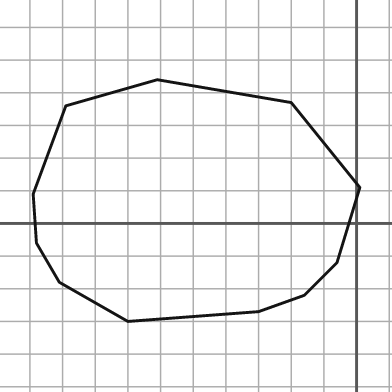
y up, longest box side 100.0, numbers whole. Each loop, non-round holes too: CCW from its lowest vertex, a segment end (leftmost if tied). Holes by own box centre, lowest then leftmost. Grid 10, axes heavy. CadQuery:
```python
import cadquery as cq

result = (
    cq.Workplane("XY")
    .moveTo(-70.0, -30.0)
    .lineTo(-30.0, -27.0)
    .lineTo(-16.0, -22.0)
    .lineTo(-6.0, -12.0)
    .lineTo(1.0, 11.0)
    .lineTo(-20.0, 37.0)
    .lineTo(-61.0, 44.0)
    .lineTo(-89.0, 36.0)
    .lineTo(-99.0, 9.0)
    .lineTo(-98.0, -6.0)
    .lineTo(-91.0, -18.0)
    .close()
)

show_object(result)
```